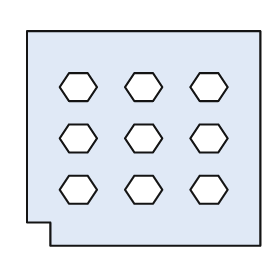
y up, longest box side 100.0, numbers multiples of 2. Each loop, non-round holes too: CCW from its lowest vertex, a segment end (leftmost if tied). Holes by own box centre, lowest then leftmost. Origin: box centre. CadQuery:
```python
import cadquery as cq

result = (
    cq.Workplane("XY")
    .moveTo(-40.0, -46.0)
    .lineTo(50.0, -46.0)
    .lineTo(50.0, 46.0)
    .lineTo(-50.0, 46.0)
    .lineTo(-50.0, -36.0)
    .lineTo(-40.0, -36.0)
    .close()
    .moveTo(-32.0, -28.0)
    .lineTo(-24.0, -28.0)
    .lineTo(-20.0, -22.0)
    .lineTo(-24.0, -16.0)
    .lineTo(-32.0, -16.0)
    .lineTo(-36.0, -22.0)
    .close()
    .moveTo(-4.0, -28.0)
    .lineTo(4.0, -28.0)
    .lineTo(8.0, -22.0)
    .lineTo(4.0, -16.0)
    .lineTo(-4.0, -16.0)
    .lineTo(-8.0, -22.0)
    .close()
    .moveTo(24.0, -28.0)
    .lineTo(32.0, -28.0)
    .lineTo(36.0, -22.0)
    .lineTo(32.0, -16.0)
    .lineTo(24.0, -16.0)
    .lineTo(20.0, -22.0)
    .close()
    .moveTo(-32.0, -6.0)
    .lineTo(-24.0, -6.0)
    .lineTo(-20.0, 0.0)
    .lineTo(-24.0, 6.0)
    .lineTo(-32.0, 6.0)
    .lineTo(-36.0, 0.0)
    .close()
    .moveTo(-4.0, -6.0)
    .lineTo(4.0, -6.0)
    .lineTo(8.0, 0.0)
    .lineTo(4.0, 6.0)
    .lineTo(-4.0, 6.0)
    .lineTo(-8.0, 0.0)
    .close()
    .moveTo(24.0, -6.0)
    .lineTo(32.0, -6.0)
    .lineTo(36.0, 0.0)
    .lineTo(32.0, 6.0)
    .lineTo(24.0, 6.0)
    .lineTo(20.0, 0.0)
    .close()
    .moveTo(-32.0, 16.0)
    .lineTo(-24.0, 16.0)
    .lineTo(-20.0, 22.0)
    .lineTo(-24.0, 28.0)
    .lineTo(-32.0, 28.0)
    .lineTo(-36.0, 22.0)
    .close()
    .moveTo(-4.0, 16.0)
    .lineTo(4.0, 16.0)
    .lineTo(8.0, 22.0)
    .lineTo(4.0, 28.0)
    .lineTo(-4.0, 28.0)
    .lineTo(-8.0, 22.0)
    .close()
    .moveTo(24.0, 16.0)
    .lineTo(32.0, 16.0)
    .lineTo(36.0, 22.0)
    .lineTo(32.0, 28.0)
    .lineTo(24.0, 28.0)
    .lineTo(20.0, 22.0)
    .close()
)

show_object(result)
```